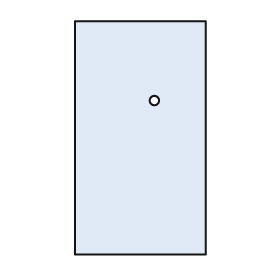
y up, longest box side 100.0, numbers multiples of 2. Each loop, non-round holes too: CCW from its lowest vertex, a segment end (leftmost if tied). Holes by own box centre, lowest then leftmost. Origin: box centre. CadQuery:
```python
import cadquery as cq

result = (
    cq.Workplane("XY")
    .moveTo(-28.0, -50.0)
    .lineTo(28.0, -50.0)
    .lineTo(28.0, 50.0)
    .lineTo(-28.0, 50.0)
    .close()
    .moveTo(6.0, 16.0)
    .circle(2.0)
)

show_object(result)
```